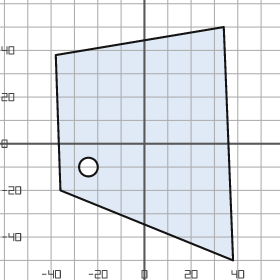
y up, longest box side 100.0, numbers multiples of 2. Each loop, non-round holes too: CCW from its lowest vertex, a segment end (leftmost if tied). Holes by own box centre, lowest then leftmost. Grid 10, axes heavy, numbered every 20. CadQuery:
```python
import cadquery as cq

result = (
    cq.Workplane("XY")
    .moveTo(38.0, -50.0)
    .lineTo(34.0, 50.0)
    .lineTo(-38.0, 38.0)
    .lineTo(-36.0, -20.0)
    .close()
    .moveTo(-24.0, -10.0)
    .circle(4.0)
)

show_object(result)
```